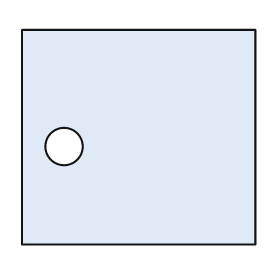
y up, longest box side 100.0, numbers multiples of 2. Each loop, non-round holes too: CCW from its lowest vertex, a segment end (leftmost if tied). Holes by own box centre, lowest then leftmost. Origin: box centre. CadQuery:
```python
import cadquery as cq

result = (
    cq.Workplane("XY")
    .moveTo(-50.0, -46.0)
    .lineTo(50.0, -46.0)
    .lineTo(50.0, 46.0)
    .lineTo(-50.0, 46.0)
    .close()
    .moveTo(-32.0, -4.0)
    .circle(8.0)
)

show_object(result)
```